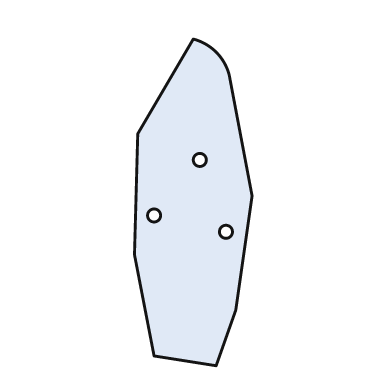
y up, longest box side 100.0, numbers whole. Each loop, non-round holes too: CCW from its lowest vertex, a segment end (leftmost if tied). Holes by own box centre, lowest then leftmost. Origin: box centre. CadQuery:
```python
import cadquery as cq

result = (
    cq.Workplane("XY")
    .moveTo(7.0, -50.0)
    .lineTo(13.0, -33.0)
    .lineTo(18.0, 2.0)
    .lineTo(11.0, 39.0)
    .threePointArc((7.0, 46.0), (0.0, 50.0))
    .lineTo(-17.0, 21.0)
    .lineTo(-18.0, -16.0)
    .lineTo(-12.0, -47.0)
    .close()
    .moveTo(10.0, -9.0)
    .circle(2.0)
    .moveTo(-12.0, -4.0)
    .circle(2.0)
    .moveTo(2.0, 13.0)
    .circle(2.0)
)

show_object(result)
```